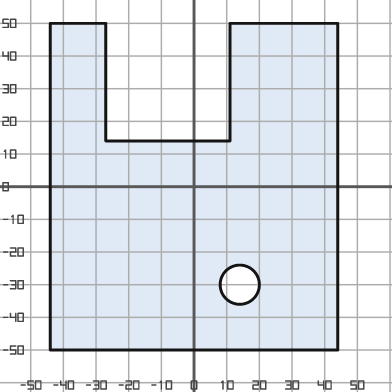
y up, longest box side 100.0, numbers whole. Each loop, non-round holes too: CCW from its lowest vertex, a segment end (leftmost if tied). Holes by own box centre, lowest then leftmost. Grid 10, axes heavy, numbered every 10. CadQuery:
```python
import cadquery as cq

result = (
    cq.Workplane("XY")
    .moveTo(-44.0, -50.0)
    .lineTo(44.0, -50.0)
    .lineTo(44.0, 50.0)
    .lineTo(11.0, 50.0)
    .lineTo(11.0, 14.0)
    .lineTo(-27.0, 14.0)
    .lineTo(-27.0, 50.0)
    .lineTo(-44.0, 50.0)
    .close()
    .moveTo(14.0, -30.0)
    .circle(6.0)
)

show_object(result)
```